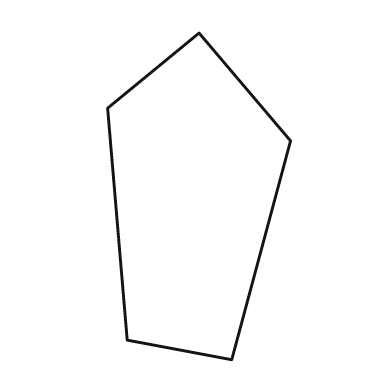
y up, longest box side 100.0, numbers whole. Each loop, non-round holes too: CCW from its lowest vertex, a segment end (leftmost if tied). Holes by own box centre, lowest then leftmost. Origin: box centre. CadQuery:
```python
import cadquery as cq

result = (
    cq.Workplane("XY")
    .moveTo(10.0, -50.0)
    .lineTo(28.0, 17.0)
    .lineTo(0.0, 50.0)
    .lineTo(-28.0, 27.0)
    .lineTo(-22.0, -44.0)
    .close()
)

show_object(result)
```